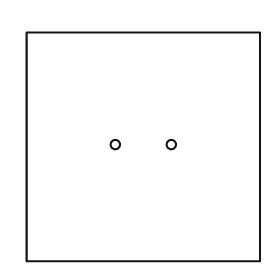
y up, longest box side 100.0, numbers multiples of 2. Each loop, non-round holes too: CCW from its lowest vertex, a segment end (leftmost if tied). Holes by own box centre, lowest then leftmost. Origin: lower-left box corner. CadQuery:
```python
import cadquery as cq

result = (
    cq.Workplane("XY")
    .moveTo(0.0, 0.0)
    .lineTo(100.0, 0.0)
    .lineTo(100.0, 98.0)
    .lineTo(0.0, 98.0)
    .close()
    .moveTo(38.0, 50.0)
    .circle(2.0)
    .moveTo(62.0, 50.0)
    .circle(2.0)
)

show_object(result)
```